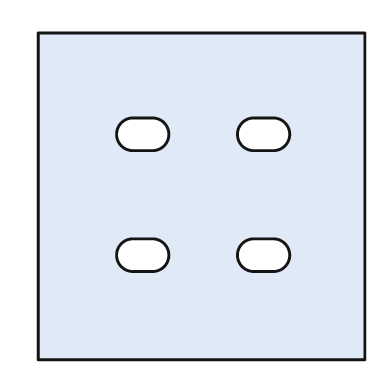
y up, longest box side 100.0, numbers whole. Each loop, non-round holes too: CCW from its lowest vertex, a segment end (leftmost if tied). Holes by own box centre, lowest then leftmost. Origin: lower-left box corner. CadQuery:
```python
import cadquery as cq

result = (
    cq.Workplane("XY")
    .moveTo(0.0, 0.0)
    .lineTo(100.0, 0.0)
    .lineTo(100.0, 100.0)
    .lineTo(0.0, 100.0)
    .close()
    .moveTo(29.0, 27.0)
    .lineTo(35.0, 27.0)
    .threePointArc((40.0, 32.0), (35.0, 37.0))
    .lineTo(29.0, 37.0)
    .threePointArc((24.0, 32.0), (29.0, 27.0))
    .close()
    .moveTo(66.0, 27.0)
    .lineTo(72.0, 27.0)
    .threePointArc((77.0, 32.0), (72.0, 37.0))
    .lineTo(66.0, 37.0)
    .threePointArc((61.0, 32.0), (66.0, 27.0))
    .close()
    .moveTo(29.0, 64.0)
    .lineTo(35.0, 64.0)
    .threePointArc((40.0, 69.0), (35.0, 74.0))
    .lineTo(29.0, 74.0)
    .threePointArc((24.0, 69.0), (29.0, 64.0))
    .close()
    .moveTo(66.0, 64.0)
    .lineTo(72.0, 64.0)
    .threePointArc((77.0, 69.0), (72.0, 74.0))
    .lineTo(66.0, 74.0)
    .threePointArc((61.0, 69.0), (66.0, 64.0))
    .close()
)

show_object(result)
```